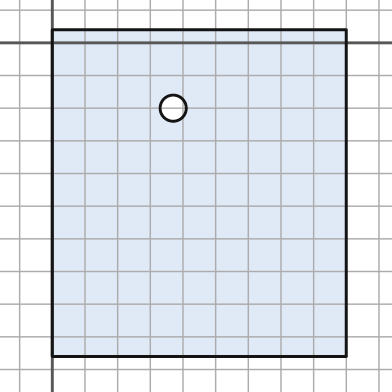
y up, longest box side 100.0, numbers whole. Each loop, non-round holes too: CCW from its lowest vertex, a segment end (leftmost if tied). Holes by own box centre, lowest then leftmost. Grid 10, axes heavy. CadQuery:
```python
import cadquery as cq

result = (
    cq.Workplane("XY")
    .moveTo(0.0, -96.0)
    .lineTo(90.0, -96.0)
    .lineTo(90.0, 4.0)
    .lineTo(0.0, 4.0)
    .close()
    .moveTo(37.0, -20.0)
    .circle(4.0)
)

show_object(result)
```